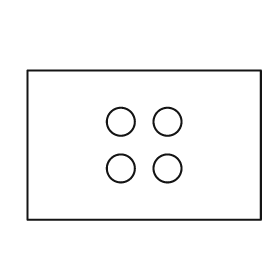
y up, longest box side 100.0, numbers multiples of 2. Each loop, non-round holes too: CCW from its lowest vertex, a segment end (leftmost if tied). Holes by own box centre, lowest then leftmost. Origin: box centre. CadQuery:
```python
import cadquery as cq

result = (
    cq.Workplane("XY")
    .moveTo(-50.0, -32.0)
    .lineTo(50.0, -32.0)
    .lineTo(50.0, 32.0)
    .lineTo(-50.0, 32.0)
    .close()
    .moveTo(-10.0, -10.0)
    .circle(6.0)
    .moveTo(10.0, -10.0)
    .circle(6.0)
    .moveTo(-10.0, 10.0)
    .circle(6.0)
    .moveTo(10.0, 10.0)
    .circle(6.0)
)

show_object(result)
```